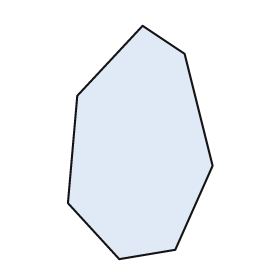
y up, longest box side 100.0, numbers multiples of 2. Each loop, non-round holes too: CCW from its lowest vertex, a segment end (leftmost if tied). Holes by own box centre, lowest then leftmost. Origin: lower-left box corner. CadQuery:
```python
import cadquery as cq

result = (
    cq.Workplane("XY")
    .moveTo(22.0, 0.0)
    .lineTo(46.0, 4.0)
    .lineTo(62.0, 40.0)
    .lineTo(50.0, 88.0)
    .lineTo(32.0, 100.0)
    .lineTo(4.0, 70.0)
    .lineTo(0.0, 24.0)
    .close()
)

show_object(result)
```